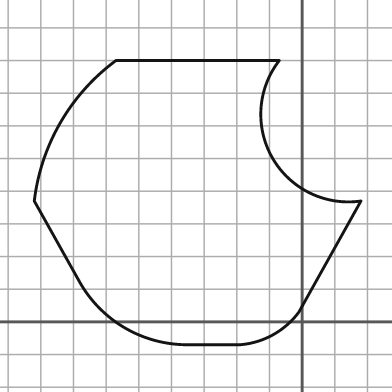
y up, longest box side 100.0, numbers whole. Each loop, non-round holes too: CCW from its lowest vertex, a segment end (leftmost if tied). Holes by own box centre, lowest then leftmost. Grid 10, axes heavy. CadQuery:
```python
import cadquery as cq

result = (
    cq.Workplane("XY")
    .moveTo(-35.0, -7.0)
    .lineTo(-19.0, -7.0)
    .threePointArc((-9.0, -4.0), (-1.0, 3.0))
    .lineTo(18.0, 37.0)
    .threePointArc((-9.0, 50.0), (-7.0, 80.0))
    .lineTo(-57.0, 80.0)
    .threePointArc((-74.0, 61.0), (-82.0, 37.0))
    .lineTo(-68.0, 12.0)
    .threePointArc((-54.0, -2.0), (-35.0, -7.0))
    .close()
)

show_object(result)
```